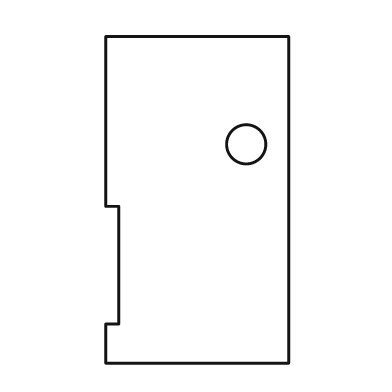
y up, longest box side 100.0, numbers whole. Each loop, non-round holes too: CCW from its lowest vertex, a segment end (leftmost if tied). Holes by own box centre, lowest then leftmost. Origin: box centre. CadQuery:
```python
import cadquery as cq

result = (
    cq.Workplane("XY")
    .moveTo(-28.0, -50.0)
    .lineTo(28.0, -50.0)
    .lineTo(28.0, 50.0)
    .lineTo(-28.0, 50.0)
    .lineTo(-28.0, -2.0)
    .lineTo(-24.0, -2.0)
    .lineTo(-24.0, -38.0)
    .lineTo(-28.0, -38.0)
    .close()
    .moveTo(15.0, 17.0)
    .circle(6.0)
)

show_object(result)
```